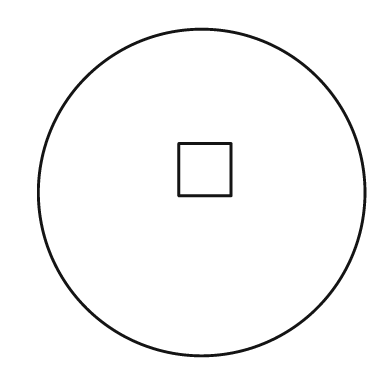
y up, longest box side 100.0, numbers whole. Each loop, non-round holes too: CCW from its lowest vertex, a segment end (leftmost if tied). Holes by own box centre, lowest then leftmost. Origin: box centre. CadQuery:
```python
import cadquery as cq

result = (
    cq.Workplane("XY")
    .moveTo(0.0, 0.0)
    .circle(50.0)
    .moveTo(-7.0, -1.0)
    .lineTo(9.0, -1.0)
    .lineTo(9.0, 15.0)
    .lineTo(-7.0, 15.0)
    .close()
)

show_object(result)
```